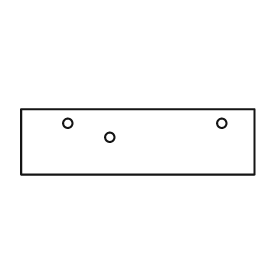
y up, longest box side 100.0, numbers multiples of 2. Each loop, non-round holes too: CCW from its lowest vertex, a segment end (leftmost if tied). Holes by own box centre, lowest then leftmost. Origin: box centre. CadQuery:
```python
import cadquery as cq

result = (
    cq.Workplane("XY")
    .moveTo(-50.0, -14.0)
    .lineTo(50.0, -14.0)
    .lineTo(50.0, 14.0)
    .lineTo(-50.0, 14.0)
    .close()
    .moveTo(-12.0, 2.0)
    .circle(2.0)
    .moveTo(-30.0, 8.0)
    .circle(2.0)
    .moveTo(36.0, 8.0)
    .circle(2.0)
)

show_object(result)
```